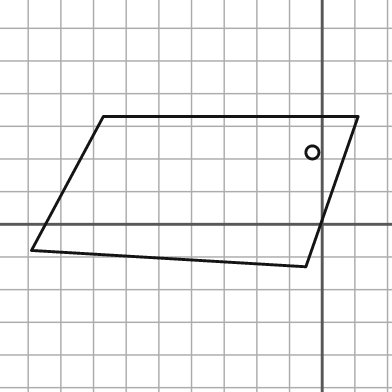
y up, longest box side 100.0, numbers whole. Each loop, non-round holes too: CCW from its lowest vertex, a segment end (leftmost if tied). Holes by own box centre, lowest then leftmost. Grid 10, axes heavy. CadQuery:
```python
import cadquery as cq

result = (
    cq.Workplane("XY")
    .moveTo(-5.0, -13.0)
    .lineTo(11.0, 33.0)
    .lineTo(-67.0, 33.0)
    .lineTo(-89.0, -8.0)
    .close()
    .moveTo(-3.0, 22.0)
    .circle(2.0)
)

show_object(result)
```